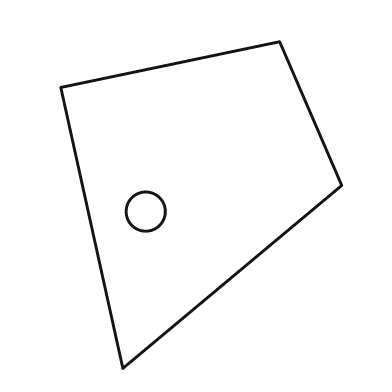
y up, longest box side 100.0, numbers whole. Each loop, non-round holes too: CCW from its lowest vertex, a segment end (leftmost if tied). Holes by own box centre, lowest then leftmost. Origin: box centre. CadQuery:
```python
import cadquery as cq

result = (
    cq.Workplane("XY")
    .moveTo(-24.0, -50.0)
    .lineTo(43.0, 6.0)
    .lineTo(24.0, 50.0)
    .lineTo(-43.0, 36.0)
    .close()
    .moveTo(-17.0, -2.0)
    .circle(6.0)
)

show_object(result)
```